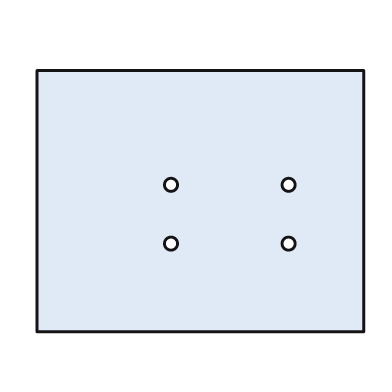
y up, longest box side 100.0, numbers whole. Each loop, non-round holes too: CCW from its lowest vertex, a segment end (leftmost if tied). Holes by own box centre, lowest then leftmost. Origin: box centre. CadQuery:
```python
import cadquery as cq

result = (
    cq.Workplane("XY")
    .moveTo(-50.0, -40.0)
    .lineTo(50.0, -40.0)
    .lineTo(50.0, 40.0)
    .lineTo(-50.0, 40.0)
    .close()
    .moveTo(-9.0, -13.0)
    .circle(2.0)
    .moveTo(27.0, -13.0)
    .circle(2.0)
    .moveTo(-9.0, 5.0)
    .circle(2.0)
    .moveTo(27.0, 5.0)
    .circle(2.0)
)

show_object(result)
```